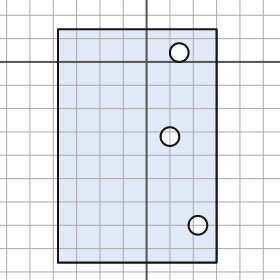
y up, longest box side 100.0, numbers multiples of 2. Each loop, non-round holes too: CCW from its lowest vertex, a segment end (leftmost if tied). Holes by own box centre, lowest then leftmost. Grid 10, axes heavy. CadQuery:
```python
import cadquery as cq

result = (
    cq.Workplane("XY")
    .moveTo(-38.0, -86.0)
    .lineTo(30.0, -86.0)
    .lineTo(30.0, 14.0)
    .lineTo(-38.0, 14.0)
    .close()
    .moveTo(22.0, -70.0)
    .circle(4.0)
    .moveTo(10.0, -32.0)
    .circle(4.0)
    .moveTo(14.0, 4.0)
    .circle(4.0)
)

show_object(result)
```